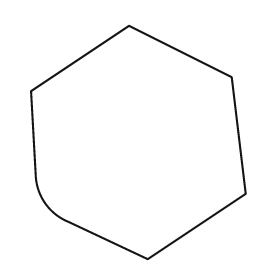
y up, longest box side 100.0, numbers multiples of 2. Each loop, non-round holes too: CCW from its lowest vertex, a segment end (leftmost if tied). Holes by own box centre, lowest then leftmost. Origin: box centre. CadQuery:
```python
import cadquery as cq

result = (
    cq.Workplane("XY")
    .moveTo(4.0, -50.0)
    .lineTo(46.0, -22.0)
    .lineTo(40.0, 28.0)
    .lineTo(-4.0, 50.0)
    .lineTo(-46.0, 22.0)
    .lineTo(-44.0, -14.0)
    .threePointArc((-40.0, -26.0), (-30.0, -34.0))
    .close()
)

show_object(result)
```